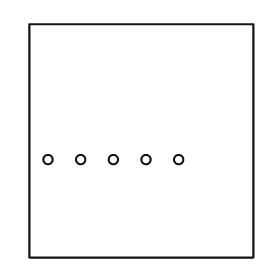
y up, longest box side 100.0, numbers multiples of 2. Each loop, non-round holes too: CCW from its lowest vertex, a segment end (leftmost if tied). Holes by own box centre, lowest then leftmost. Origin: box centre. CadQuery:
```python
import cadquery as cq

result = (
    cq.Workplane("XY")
    .moveTo(-48.0, -50.0)
    .lineTo(48.0, -50.0)
    .lineTo(48.0, 50.0)
    .lineTo(-48.0, 50.0)
    .close()
    .moveTo(-40.0, -8.0)
    .circle(2.0)
    .moveTo(-26.0, -8.0)
    .circle(2.0)
    .moveTo(-12.0, -8.0)
    .circle(2.0)
    .moveTo(2.0, -8.0)
    .circle(2.0)
    .moveTo(16.0, -8.0)
    .circle(2.0)
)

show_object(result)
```